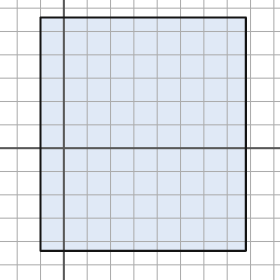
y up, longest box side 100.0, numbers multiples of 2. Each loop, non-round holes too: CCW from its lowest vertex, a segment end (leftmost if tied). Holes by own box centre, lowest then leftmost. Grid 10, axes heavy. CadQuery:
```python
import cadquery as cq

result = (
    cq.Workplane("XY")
    .moveTo(-10.0, -44.0)
    .lineTo(78.0, -44.0)
    .lineTo(78.0, 56.0)
    .lineTo(-10.0, 56.0)
    .close()
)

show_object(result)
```